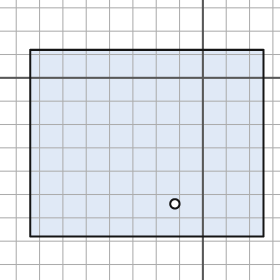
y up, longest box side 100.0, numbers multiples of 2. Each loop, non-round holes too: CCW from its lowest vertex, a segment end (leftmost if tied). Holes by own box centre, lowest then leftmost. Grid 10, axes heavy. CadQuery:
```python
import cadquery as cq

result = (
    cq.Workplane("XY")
    .moveTo(-74.0, -68.0)
    .lineTo(26.0, -68.0)
    .lineTo(26.0, 12.0)
    .lineTo(-74.0, 12.0)
    .close()
    .moveTo(-12.0, -54.0)
    .circle(2.0)
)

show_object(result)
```